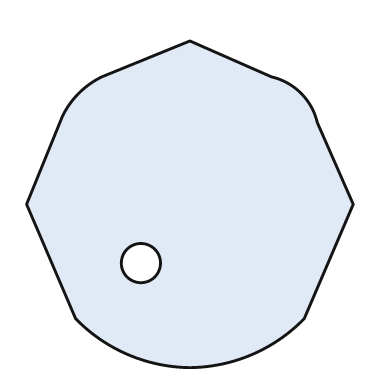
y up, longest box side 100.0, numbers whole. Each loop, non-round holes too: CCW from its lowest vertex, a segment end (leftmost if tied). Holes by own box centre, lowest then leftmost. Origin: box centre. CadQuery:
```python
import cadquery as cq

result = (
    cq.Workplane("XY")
    .moveTo(0.0, -50.0)
    .threePointArc((19.0, -46.0), (35.0, -35.0))
    .lineTo(50.0, 0.0)
    .lineTo(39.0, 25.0)
    .threePointArc((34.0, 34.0), (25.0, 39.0))
    .lineTo(0.0, 50.0)
    .lineTo(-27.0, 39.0)
    .threePointArc((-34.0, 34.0), (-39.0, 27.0))
    .lineTo(-50.0, 0.0)
    .lineTo(-35.0, -35.0)
    .threePointArc((-19.0, -46.0), (0.0, -50.0))
    .close()
    .moveTo(-15.0, -18.0)
    .circle(6.0)
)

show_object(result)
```